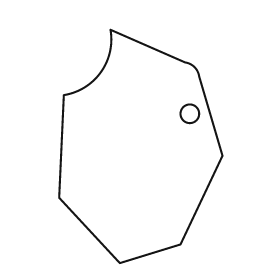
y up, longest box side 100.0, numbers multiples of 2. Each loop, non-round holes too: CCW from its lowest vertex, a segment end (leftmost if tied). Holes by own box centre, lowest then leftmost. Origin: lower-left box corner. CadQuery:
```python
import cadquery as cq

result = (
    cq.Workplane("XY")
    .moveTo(26.0, 0.0)
    .lineTo(52.0, 8.0)
    .lineTo(70.0, 46.0)
    .lineTo(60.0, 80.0)
    .threePointArc((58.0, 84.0), (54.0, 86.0))
    .lineTo(22.0, 100.0)
    .threePointArc((18.0, 82.0), (2.0, 72.0))
    .lineTo(0.0, 28.0)
    .close()
    .moveTo(56.0, 64.0)
    .circle(4.0)
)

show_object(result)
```